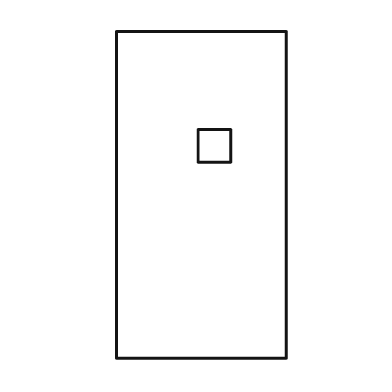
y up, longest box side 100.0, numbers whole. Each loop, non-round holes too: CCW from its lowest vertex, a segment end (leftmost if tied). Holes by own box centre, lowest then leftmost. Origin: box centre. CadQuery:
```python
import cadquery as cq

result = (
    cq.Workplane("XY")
    .moveTo(-26.0, -50.0)
    .lineTo(26.0, -50.0)
    .lineTo(26.0, 50.0)
    .lineTo(-26.0, 50.0)
    .close()
    .moveTo(-1.0, 10.0)
    .lineTo(9.0, 10.0)
    .lineTo(9.0, 20.0)
    .lineTo(-1.0, 20.0)
    .close()
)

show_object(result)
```